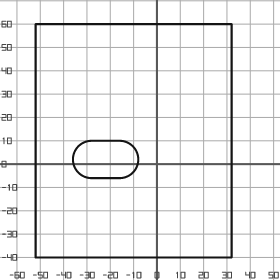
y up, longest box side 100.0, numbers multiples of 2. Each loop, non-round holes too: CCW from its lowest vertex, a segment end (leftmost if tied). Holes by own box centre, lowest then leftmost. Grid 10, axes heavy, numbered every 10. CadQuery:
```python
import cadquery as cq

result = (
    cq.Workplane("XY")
    .moveTo(-52.0, -40.0)
    .lineTo(32.0, -40.0)
    .lineTo(32.0, 60.0)
    .lineTo(-52.0, 60.0)
    .close()
    .moveTo(-28.0, -6.0)
    .lineTo(-16.0, -6.0)
    .threePointArc((-8.0, 2.0), (-16.0, 10.0))
    .lineTo(-28.0, 10.0)
    .threePointArc((-36.0, 2.0), (-28.0, -6.0))
    .close()
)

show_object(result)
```